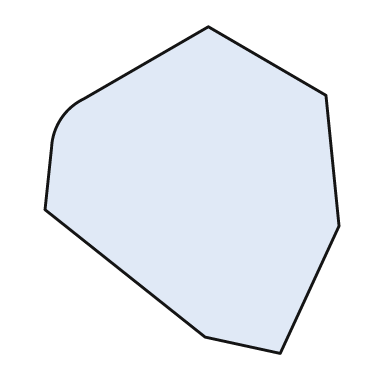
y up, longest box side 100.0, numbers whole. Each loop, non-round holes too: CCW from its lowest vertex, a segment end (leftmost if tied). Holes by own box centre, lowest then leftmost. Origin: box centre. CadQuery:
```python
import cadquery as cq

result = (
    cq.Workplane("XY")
    .moveTo(27.0, -50.0)
    .lineTo(45.0, -11.0)
    .lineTo(41.0, 29.0)
    .lineTo(5.0, 50.0)
    .lineTo(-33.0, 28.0)
    .threePointArc((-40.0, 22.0), (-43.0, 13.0))
    .lineTo(-45.0, -6.0)
    .lineTo(4.0, -45.0)
    .close()
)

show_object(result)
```